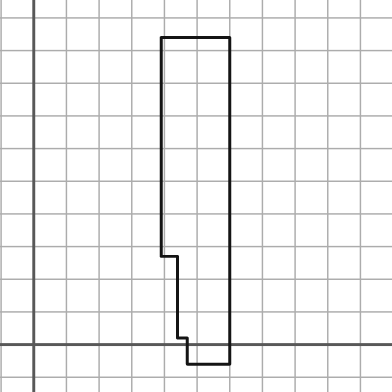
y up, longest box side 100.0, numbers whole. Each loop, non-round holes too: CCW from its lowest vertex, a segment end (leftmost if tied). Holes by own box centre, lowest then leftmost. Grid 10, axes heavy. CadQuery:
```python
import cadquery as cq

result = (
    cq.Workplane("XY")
    .moveTo(47.0, -6.0)
    .lineTo(60.0, -6.0)
    .lineTo(60.0, 94.0)
    .lineTo(39.0, 94.0)
    .lineTo(39.0, 27.0)
    .lineTo(44.0, 27.0)
    .lineTo(44.0, 2.0)
    .lineTo(47.0, 2.0)
    .close()
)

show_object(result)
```